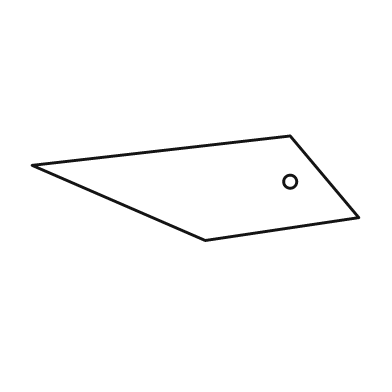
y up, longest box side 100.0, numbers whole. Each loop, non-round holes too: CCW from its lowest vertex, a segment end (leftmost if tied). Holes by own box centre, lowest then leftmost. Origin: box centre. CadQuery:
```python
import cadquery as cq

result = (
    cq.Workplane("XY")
    .moveTo(3.0, -16.0)
    .lineTo(50.0, -9.0)
    .lineTo(29.0, 16.0)
    .lineTo(-50.0, 7.0)
    .close()
    .moveTo(29.0, 2.0)
    .circle(2.0)
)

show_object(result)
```